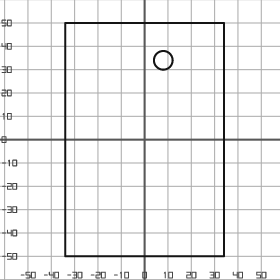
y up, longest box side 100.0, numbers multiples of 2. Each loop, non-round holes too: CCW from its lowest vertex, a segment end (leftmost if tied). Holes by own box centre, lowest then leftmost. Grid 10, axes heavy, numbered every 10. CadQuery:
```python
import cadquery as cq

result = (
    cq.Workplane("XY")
    .moveTo(-34.0, -50.0)
    .lineTo(34.0, -50.0)
    .lineTo(34.0, 50.0)
    .lineTo(-34.0, 50.0)
    .close()
    .moveTo(8.0, 34.0)
    .circle(4.0)
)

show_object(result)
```